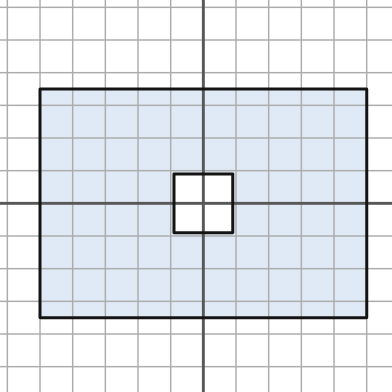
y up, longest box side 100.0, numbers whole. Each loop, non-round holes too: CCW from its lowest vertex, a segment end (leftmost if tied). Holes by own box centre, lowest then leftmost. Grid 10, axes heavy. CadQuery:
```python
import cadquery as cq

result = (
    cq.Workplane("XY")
    .moveTo(-50.0, -35.0)
    .lineTo(50.0, -35.0)
    .lineTo(50.0, 35.0)
    .lineTo(-50.0, 35.0)
    .close()
    .moveTo(-9.0, -9.0)
    .lineTo(9.0, -9.0)
    .lineTo(9.0, 9.0)
    .lineTo(-9.0, 9.0)
    .close()
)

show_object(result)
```